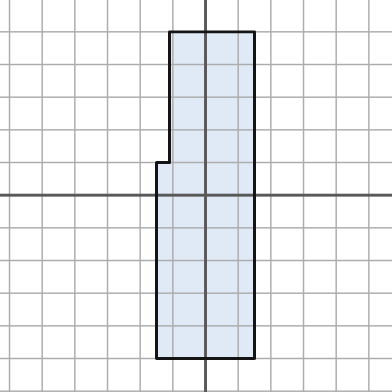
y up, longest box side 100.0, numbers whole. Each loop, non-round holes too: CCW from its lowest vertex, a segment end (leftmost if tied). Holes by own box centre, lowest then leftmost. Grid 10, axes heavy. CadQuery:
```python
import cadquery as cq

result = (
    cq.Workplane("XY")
    .moveTo(-15.0, -50.0)
    .lineTo(15.0, -50.0)
    .lineTo(15.0, 50.0)
    .lineTo(-11.0, 50.0)
    .lineTo(-11.0, 10.0)
    .lineTo(-15.0, 10.0)
    .close()
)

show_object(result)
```